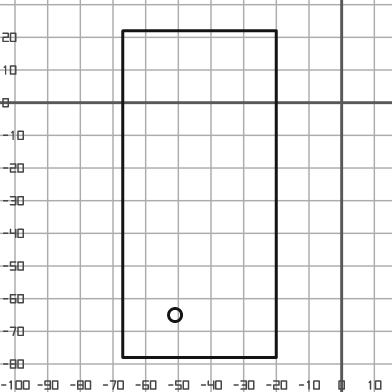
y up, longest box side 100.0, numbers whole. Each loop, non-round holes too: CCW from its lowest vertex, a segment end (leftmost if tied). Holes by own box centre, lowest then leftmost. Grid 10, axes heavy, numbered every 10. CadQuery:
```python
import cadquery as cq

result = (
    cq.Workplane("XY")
    .moveTo(-67.0, -78.0)
    .lineTo(-20.0, -78.0)
    .lineTo(-20.0, 22.0)
    .lineTo(-67.0, 22.0)
    .close()
    .moveTo(-51.0, -65.0)
    .circle(2.0)
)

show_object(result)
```